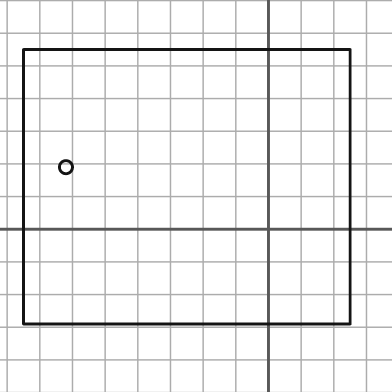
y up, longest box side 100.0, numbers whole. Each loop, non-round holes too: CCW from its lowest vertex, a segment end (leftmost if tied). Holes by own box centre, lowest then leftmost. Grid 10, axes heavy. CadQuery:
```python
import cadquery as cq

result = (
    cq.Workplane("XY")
    .moveTo(-75.0, -29.0)
    .lineTo(25.0, -29.0)
    .lineTo(25.0, 55.0)
    .lineTo(-75.0, 55.0)
    .close()
    .moveTo(-62.0, 19.0)
    .circle(2.0)
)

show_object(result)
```